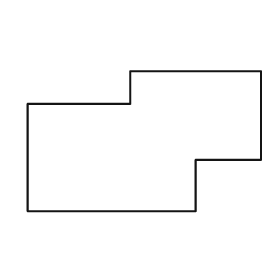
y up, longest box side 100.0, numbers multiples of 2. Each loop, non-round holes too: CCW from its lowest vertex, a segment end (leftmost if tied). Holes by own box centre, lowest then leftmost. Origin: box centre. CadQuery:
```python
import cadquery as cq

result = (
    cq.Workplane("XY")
    .moveTo(-50.0, -30.0)
    .lineTo(22.0, -30.0)
    .lineTo(22.0, -8.0)
    .lineTo(50.0, -8.0)
    .lineTo(50.0, 30.0)
    .lineTo(-6.0, 30.0)
    .lineTo(-6.0, 16.0)
    .lineTo(-50.0, 16.0)
    .close()
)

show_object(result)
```